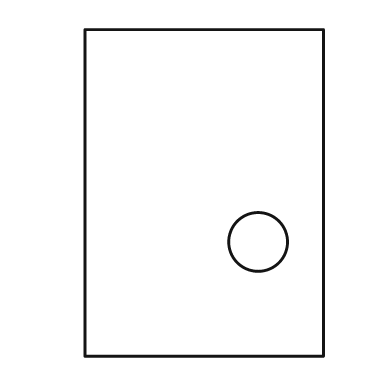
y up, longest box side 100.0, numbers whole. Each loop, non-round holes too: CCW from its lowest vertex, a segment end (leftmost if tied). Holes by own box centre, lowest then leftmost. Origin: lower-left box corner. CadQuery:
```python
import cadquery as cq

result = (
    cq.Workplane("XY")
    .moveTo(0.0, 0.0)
    .lineTo(73.0, 0.0)
    .lineTo(73.0, 100.0)
    .lineTo(0.0, 100.0)
    .close()
    .moveTo(53.0, 35.0)
    .circle(9.0)
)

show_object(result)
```